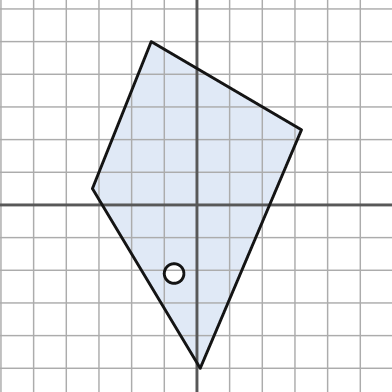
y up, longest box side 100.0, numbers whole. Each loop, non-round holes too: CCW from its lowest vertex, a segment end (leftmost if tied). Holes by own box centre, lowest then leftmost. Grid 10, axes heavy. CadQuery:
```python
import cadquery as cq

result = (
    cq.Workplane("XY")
    .moveTo(1.0, -50.0)
    .lineTo(32.0, 23.0)
    .lineTo(-14.0, 50.0)
    .lineTo(-32.0, 5.0)
    .close()
    .moveTo(-7.0, -21.0)
    .circle(3.0)
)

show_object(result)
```